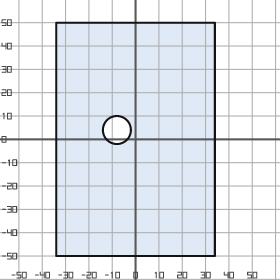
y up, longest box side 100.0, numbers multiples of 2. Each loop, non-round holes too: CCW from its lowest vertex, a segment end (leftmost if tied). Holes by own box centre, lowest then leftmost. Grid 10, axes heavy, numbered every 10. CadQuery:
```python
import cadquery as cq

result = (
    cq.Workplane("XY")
    .moveTo(-34.0, -50.0)
    .lineTo(34.0, -50.0)
    .lineTo(34.0, 50.0)
    .lineTo(-34.0, 50.0)
    .close()
    .moveTo(-8.0, 4.0)
    .circle(6.0)
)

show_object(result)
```